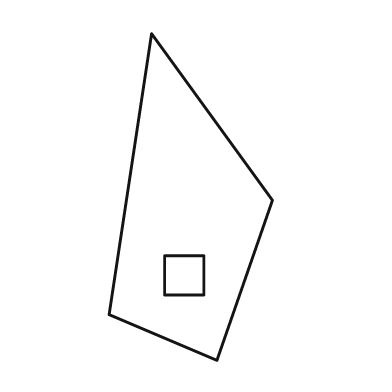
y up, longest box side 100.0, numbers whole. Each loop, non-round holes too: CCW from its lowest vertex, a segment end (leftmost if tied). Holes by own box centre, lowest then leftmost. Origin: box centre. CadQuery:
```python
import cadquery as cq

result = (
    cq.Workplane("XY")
    .moveTo(8.0, -50.0)
    .lineTo(25.0, -1.0)
    .lineTo(-12.0, 50.0)
    .lineTo(-25.0, -36.0)
    .close()
    .moveTo(-8.0, -30.0)
    .lineTo(4.0, -30.0)
    .lineTo(4.0, -18.0)
    .lineTo(-8.0, -18.0)
    .close()
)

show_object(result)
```